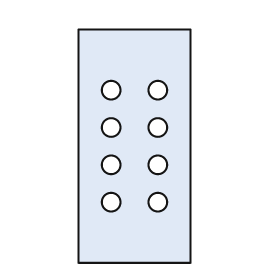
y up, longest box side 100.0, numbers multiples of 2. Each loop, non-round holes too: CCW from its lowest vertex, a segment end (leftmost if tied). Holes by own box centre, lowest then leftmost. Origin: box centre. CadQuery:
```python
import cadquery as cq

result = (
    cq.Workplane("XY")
    .moveTo(-24.0, -50.0)
    .lineTo(24.0, -50.0)
    .lineTo(24.0, 50.0)
    .lineTo(-24.0, 50.0)
    .close()
    .moveTo(-10.0, -24.0)
    .circle(4.0)
    .moveTo(10.0, -24.0)
    .circle(4.0)
    .moveTo(-10.0, -8.0)
    .circle(4.0)
    .moveTo(10.0, -8.0)
    .circle(4.0)
    .moveTo(-10.0, 8.0)
    .circle(4.0)
    .moveTo(10.0, 8.0)
    .circle(4.0)
    .moveTo(-10.0, 24.0)
    .circle(4.0)
    .moveTo(10.0, 24.0)
    .circle(4.0)
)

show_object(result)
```